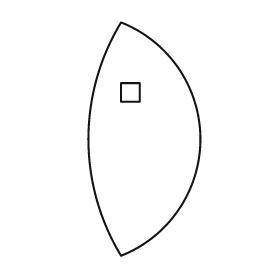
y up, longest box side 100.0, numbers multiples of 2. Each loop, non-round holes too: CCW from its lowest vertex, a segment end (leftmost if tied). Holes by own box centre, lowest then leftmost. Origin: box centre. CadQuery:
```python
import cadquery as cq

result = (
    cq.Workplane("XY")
    .moveTo(-10.0, -50.0)
    .threePointArc((24.0, 0.0), (-10.0, 50.0))
    .threePointArc((-24.0, 0.0), (-10.0, -50.0))
    .close()
    .moveTo(-10.0, 16.0)
    .lineTo(-2.0, 16.0)
    .lineTo(-2.0, 24.0)
    .lineTo(-10.0, 24.0)
    .close()
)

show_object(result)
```